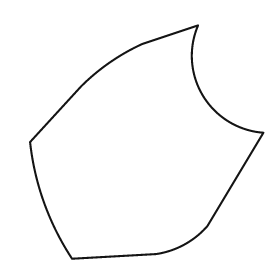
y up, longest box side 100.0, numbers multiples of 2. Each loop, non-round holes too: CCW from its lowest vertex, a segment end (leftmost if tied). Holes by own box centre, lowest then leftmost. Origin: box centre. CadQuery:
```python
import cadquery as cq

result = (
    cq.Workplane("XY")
    .moveTo(-32.0, -50.0)
    .lineTo(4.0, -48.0)
    .threePointArc((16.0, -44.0), (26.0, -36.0))
    .lineTo(50.0, 4.0)
    .threePointArc((24.0, 20.0), (22.0, 50.0))
    .lineTo(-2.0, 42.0)
    .threePointArc((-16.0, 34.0), (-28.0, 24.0))
    .lineTo(-50.0, 0.0)
    .threePointArc((-44.0, -26.0), (-32.0, -50.0))
    .close()
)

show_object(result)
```